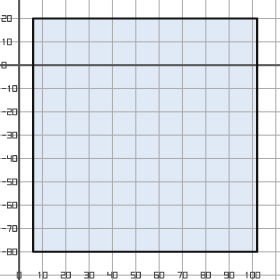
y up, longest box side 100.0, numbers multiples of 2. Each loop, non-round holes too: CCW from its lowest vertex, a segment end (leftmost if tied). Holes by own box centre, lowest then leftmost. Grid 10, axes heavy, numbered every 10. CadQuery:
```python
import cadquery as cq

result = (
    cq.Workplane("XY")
    .moveTo(6.0, -80.0)
    .lineTo(102.0, -80.0)
    .lineTo(102.0, 20.0)
    .lineTo(6.0, 20.0)
    .close()
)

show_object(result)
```